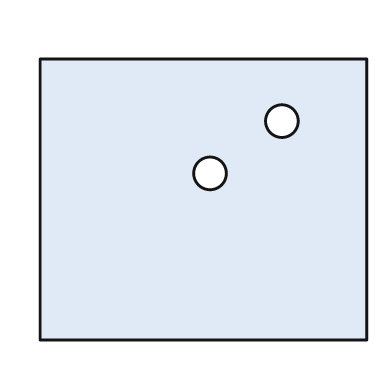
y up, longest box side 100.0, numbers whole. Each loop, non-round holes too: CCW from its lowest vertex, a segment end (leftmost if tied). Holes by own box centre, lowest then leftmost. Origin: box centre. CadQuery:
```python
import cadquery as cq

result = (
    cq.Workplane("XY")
    .moveTo(-50.0, -43.0)
    .lineTo(50.0, -43.0)
    .lineTo(50.0, 43.0)
    .lineTo(-50.0, 43.0)
    .close()
    .moveTo(2.0, 8.0)
    .circle(5.0)
    .moveTo(24.0, 24.0)
    .circle(5.0)
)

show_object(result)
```